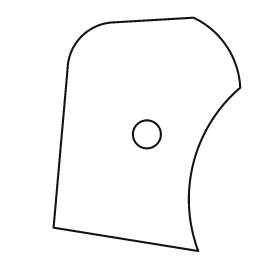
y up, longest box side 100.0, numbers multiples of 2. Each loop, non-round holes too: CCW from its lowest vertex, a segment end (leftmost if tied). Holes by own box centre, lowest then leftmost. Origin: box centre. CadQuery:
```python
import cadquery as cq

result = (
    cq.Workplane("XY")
    .moveTo(22.0, -50.0)
    .threePointArc((20.0, -12.0), (40.0, 20.0))
    .threePointArc((34.0, 38.0), (20.0, 50.0))
    .lineTo(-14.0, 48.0)
    .threePointArc((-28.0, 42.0), (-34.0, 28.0))
    .lineTo(-40.0, -40.0)
    .close()
    .moveTo(0.0, 0.0)
    .circle(6.0)
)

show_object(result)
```